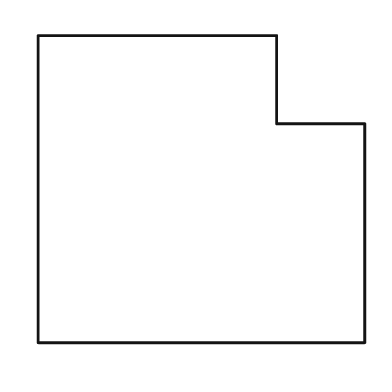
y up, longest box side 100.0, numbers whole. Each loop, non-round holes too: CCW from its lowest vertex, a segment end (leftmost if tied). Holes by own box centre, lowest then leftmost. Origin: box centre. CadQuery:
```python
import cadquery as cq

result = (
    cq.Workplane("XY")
    .moveTo(-50.0, -47.0)
    .lineTo(50.0, -47.0)
    .lineTo(50.0, 20.0)
    .lineTo(23.0, 20.0)
    .lineTo(23.0, 47.0)
    .lineTo(-50.0, 47.0)
    .close()
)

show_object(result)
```